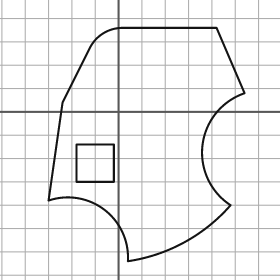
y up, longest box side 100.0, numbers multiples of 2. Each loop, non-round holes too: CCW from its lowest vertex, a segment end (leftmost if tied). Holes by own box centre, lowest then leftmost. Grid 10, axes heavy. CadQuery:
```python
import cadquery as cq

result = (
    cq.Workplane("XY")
    .moveTo(4.0, -64.0)
    .threePointArc((28.0, -56.0), (48.0, -40.0))
    .threePointArc((36.0, -14.0), (54.0, 8.0))
    .lineTo(42.0, 36.0)
    .lineTo(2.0, 36.0)
    .threePointArc((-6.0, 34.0), (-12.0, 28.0))
    .lineTo(-24.0, 4.0)
    .lineTo(-30.0, -38.0)
    .threePointArc((-6.0, -42.0), (4.0, -64.0))
    .close()
    .moveTo(-18.0, -30.0)
    .lineTo(-2.0, -30.0)
    .lineTo(-2.0, -14.0)
    .lineTo(-18.0, -14.0)
    .close()
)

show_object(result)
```